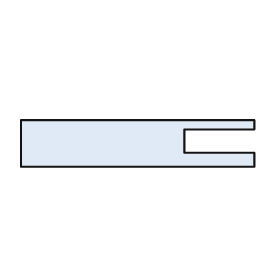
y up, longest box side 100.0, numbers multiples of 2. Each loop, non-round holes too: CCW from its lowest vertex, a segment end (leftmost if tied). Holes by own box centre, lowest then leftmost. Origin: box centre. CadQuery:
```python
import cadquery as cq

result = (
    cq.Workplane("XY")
    .moveTo(-50.0, -10.0)
    .lineTo(50.0, -10.0)
    .lineTo(50.0, -4.0)
    .lineTo(20.0, -4.0)
    .lineTo(20.0, 6.0)
    .lineTo(50.0, 6.0)
    .lineTo(50.0, 10.0)
    .lineTo(-50.0, 10.0)
    .close()
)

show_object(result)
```